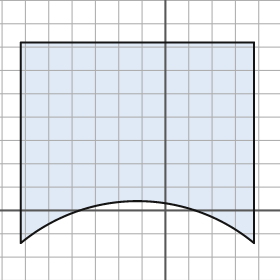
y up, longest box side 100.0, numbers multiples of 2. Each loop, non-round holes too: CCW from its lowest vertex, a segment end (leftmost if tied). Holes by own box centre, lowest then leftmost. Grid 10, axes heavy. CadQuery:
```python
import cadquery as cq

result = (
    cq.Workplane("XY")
    .moveTo(-62.0, -14.0)
    .threePointArc((-12.0, 4.0), (38.0, -14.0))
    .lineTo(38.0, 72.0)
    .lineTo(-62.0, 72.0)
    .close()
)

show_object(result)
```